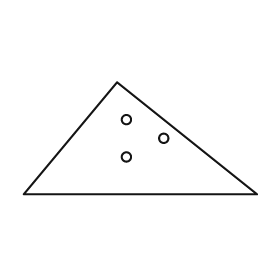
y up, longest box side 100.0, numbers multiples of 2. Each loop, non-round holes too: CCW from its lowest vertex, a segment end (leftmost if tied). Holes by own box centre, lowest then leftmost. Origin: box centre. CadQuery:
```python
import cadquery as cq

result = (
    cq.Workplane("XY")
    .moveTo(-50.0, -24.0)
    .lineTo(50.0, -24.0)
    .lineTo(-10.0, 24.0)
    .close()
    .moveTo(-6.0, -8.0)
    .circle(2.0)
    .moveTo(10.0, 0.0)
    .circle(2.0)
    .moveTo(-6.0, 8.0)
    .circle(2.0)
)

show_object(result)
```